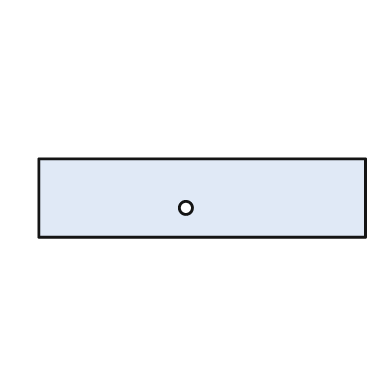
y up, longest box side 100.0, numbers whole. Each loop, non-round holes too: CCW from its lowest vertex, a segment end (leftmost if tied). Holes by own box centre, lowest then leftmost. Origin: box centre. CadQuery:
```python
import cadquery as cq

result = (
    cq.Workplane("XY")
    .moveTo(-50.0, -12.0)
    .lineTo(50.0, -12.0)
    .lineTo(50.0, 12.0)
    .lineTo(-50.0, 12.0)
    .close()
    .moveTo(-5.0, -3.0)
    .circle(2.0)
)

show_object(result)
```